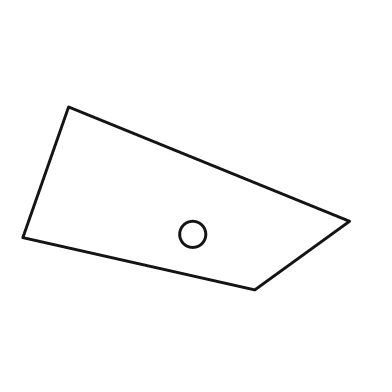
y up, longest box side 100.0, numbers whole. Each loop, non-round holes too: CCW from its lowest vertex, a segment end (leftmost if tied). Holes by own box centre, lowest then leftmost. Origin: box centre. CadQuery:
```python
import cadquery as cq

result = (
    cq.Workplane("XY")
    .moveTo(21.0, -28.0)
    .lineTo(50.0, -7.0)
    .lineTo(-36.0, 28.0)
    .lineTo(-50.0, -12.0)
    .close()
    .moveTo(2.0, -11.0)
    .circle(4.0)
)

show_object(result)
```